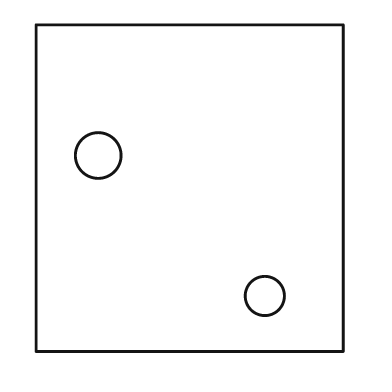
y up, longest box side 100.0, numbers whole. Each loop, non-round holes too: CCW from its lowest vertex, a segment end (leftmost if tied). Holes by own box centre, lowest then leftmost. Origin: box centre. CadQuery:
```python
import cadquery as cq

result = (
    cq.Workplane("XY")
    .moveTo(-47.0, -50.0)
    .lineTo(47.0, -50.0)
    .lineTo(47.0, 50.0)
    .lineTo(-47.0, 50.0)
    .close()
    .moveTo(23.0, -33.0)
    .circle(6.0)
    .moveTo(-28.0, 10.0)
    .circle(7.0)
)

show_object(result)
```